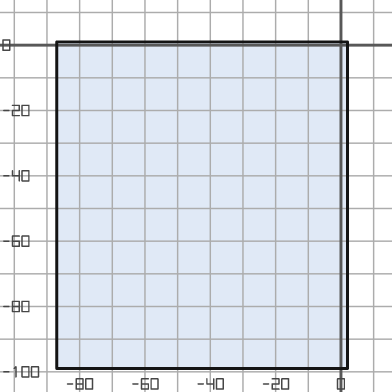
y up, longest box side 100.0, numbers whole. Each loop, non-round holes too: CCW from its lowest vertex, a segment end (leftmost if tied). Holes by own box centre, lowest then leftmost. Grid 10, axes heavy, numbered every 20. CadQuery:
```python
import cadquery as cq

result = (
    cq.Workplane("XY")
    .moveTo(-87.0, -99.0)
    .lineTo(2.0, -99.0)
    .lineTo(2.0, 1.0)
    .lineTo(-87.0, 1.0)
    .close()
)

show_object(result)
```